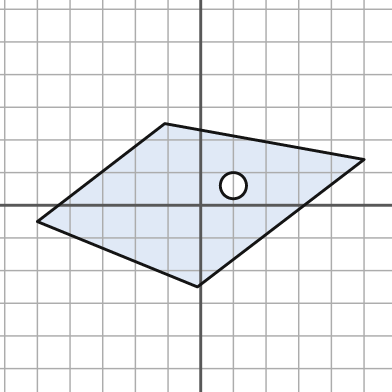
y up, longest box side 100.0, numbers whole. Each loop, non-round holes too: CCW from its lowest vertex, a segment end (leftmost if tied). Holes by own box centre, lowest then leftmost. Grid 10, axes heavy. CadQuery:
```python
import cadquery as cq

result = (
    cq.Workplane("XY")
    .moveTo(-1.0, -25.0)
    .lineTo(50.0, 14.0)
    .lineTo(-11.0, 25.0)
    .lineTo(-50.0, -5.0)
    .close()
    .moveTo(10.0, 6.0)
    .circle(4.0)
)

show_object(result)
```